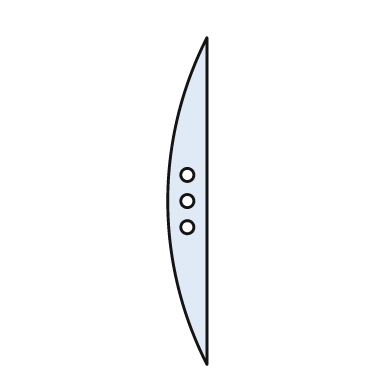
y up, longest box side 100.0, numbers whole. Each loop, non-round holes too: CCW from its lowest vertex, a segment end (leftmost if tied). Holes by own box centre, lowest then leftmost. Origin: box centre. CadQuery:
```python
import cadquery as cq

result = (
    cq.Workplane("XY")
    .moveTo(6.0, -50.0)
    .lineTo(6.0, 50.0)
    .threePointArc((-6.0, 0.0), (6.0, -50.0))
    .close()
    .moveTo(0.0, -8.0)
    .circle(2.0)
    .moveTo(0.0, 0.0)
    .circle(2.0)
    .moveTo(0.0, 8.0)
    .circle(2.0)
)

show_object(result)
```